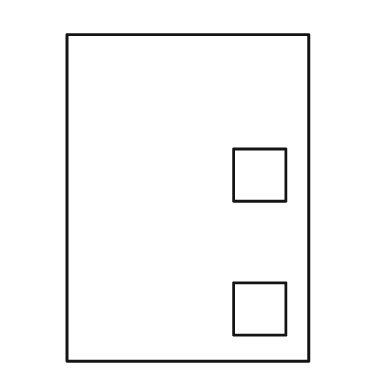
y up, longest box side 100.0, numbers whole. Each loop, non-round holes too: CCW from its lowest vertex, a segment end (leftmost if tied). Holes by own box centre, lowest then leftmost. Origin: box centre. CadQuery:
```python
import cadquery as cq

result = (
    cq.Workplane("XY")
    .moveTo(-37.0, -50.0)
    .lineTo(37.0, -50.0)
    .lineTo(37.0, 50.0)
    .lineTo(-37.0, 50.0)
    .close()
    .moveTo(14.0, -42.0)
    .lineTo(30.0, -42.0)
    .lineTo(30.0, -26.0)
    .lineTo(14.0, -26.0)
    .close()
    .moveTo(14.0, -1.0)
    .lineTo(30.0, -1.0)
    .lineTo(30.0, 15.0)
    .lineTo(14.0, 15.0)
    .close()
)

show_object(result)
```